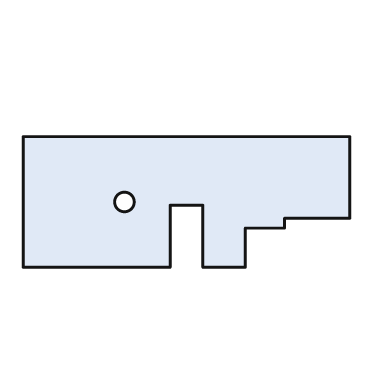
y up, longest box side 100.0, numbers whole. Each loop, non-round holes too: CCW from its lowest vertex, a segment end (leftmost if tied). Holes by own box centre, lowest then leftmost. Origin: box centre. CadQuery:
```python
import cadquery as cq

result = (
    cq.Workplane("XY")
    .moveTo(-50.0, -20.0)
    .lineTo(-5.0, -20.0)
    .lineTo(-5.0, -1.0)
    .lineTo(5.0, -1.0)
    .lineTo(5.0, -20.0)
    .lineTo(18.0, -20.0)
    .lineTo(18.0, -8.0)
    .lineTo(30.0, -8.0)
    .lineTo(30.0, -5.0)
    .lineTo(50.0, -5.0)
    .lineTo(50.0, 20.0)
    .lineTo(-50.0, 20.0)
    .close()
    .moveTo(-19.0, 0.0)
    .circle(3.0)
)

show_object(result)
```